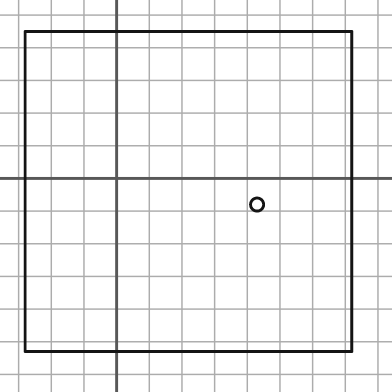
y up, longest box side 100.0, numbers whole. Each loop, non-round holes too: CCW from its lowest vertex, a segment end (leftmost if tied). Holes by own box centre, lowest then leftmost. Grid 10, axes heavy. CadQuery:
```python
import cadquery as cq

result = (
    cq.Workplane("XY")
    .moveTo(-28.0, -53.0)
    .lineTo(72.0, -53.0)
    .lineTo(72.0, 45.0)
    .lineTo(-28.0, 45.0)
    .close()
    .moveTo(43.0, -8.0)
    .circle(2.0)
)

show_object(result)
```